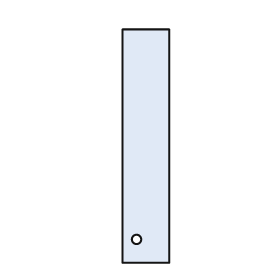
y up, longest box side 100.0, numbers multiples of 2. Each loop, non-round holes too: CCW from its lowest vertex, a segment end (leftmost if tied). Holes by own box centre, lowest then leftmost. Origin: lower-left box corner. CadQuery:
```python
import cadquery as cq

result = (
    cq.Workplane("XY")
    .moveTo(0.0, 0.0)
    .lineTo(20.0, 0.0)
    .lineTo(20.0, 100.0)
    .lineTo(0.0, 100.0)
    .close()
    .moveTo(6.0, 10.0)
    .circle(2.0)
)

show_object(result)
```